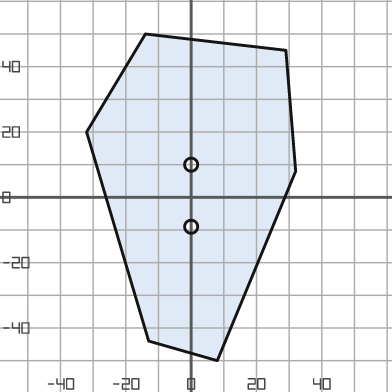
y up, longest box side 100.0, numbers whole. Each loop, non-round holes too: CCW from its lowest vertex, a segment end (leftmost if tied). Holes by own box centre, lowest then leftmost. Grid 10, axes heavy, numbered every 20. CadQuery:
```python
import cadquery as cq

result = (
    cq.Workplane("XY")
    .moveTo(8.0, -50.0)
    .lineTo(32.0, 8.0)
    .lineTo(29.0, 45.0)
    .lineTo(-14.0, 50.0)
    .lineTo(-32.0, 20.0)
    .lineTo(-13.0, -44.0)
    .close()
    .moveTo(0.0, -9.0)
    .circle(2.0)
    .moveTo(0.0, 10.0)
    .circle(2.0)
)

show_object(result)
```